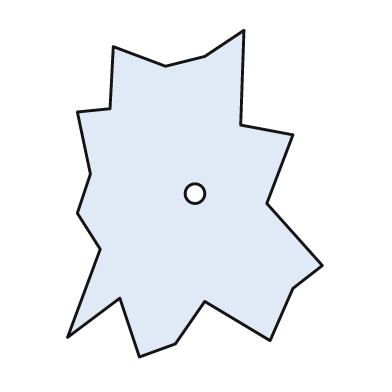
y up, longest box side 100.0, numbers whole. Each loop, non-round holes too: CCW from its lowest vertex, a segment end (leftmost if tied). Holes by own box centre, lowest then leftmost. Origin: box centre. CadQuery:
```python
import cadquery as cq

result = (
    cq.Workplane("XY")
    .moveTo(-17.0, -50.0)
    .lineTo(-6.0, -46.0)
    .lineTo(3.0, -33.0)
    .lineTo(23.0, -45.0)
    .lineTo(30.0, -29.0)
    .lineTo(39.0, -22.0)
    .lineTo(22.0, -3.0)
    .lineTo(30.0, 18.0)
    .lineTo(14.0, 21.0)
    .lineTo(15.0, 50.0)
    .lineTo(3.0, 42.0)
    .lineTo(-9.0, 39.0)
    .lineTo(-25.0, 45.0)
    .lineTo(-26.0, 26.0)
    .lineTo(-36.0, 25.0)
    .lineTo(-32.0, 6.0)
    .lineTo(-36.0, -6.0)
    .lineTo(-29.0, -17.0)
    .lineTo(-39.0, -44.0)
    .lineTo(-23.0, -32.0)
    .close()
    .moveTo(0.0, 0.0)
    .circle(3.0)
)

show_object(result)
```